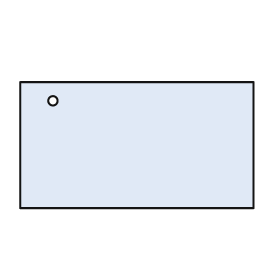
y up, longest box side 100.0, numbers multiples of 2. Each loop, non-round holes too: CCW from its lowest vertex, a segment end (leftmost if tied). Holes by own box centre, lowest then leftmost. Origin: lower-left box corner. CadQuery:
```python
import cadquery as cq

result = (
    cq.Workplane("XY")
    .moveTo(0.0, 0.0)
    .lineTo(100.0, 0.0)
    .lineTo(100.0, 54.0)
    .lineTo(0.0, 54.0)
    .close()
    .moveTo(14.0, 46.0)
    .circle(2.0)
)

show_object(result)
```